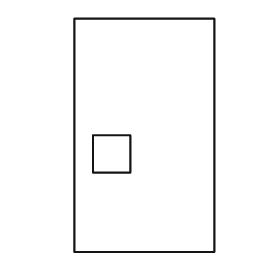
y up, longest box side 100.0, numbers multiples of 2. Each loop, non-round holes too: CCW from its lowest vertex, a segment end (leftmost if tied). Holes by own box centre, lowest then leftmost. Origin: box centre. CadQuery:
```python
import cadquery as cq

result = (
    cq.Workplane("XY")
    .moveTo(-30.0, -50.0)
    .lineTo(30.0, -50.0)
    .lineTo(30.0, 50.0)
    .lineTo(-30.0, 50.0)
    .close()
    .moveTo(-22.0, -16.0)
    .lineTo(-6.0, -16.0)
    .lineTo(-6.0, 0.0)
    .lineTo(-22.0, 0.0)
    .close()
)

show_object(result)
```